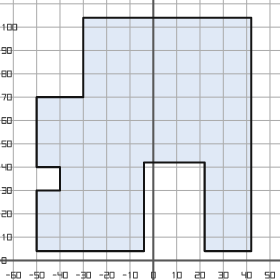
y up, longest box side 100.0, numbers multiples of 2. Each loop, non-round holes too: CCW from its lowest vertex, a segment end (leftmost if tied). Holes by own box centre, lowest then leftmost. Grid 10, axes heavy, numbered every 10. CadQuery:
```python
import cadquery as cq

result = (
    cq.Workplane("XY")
    .moveTo(-50.0, 4.0)
    .lineTo(-4.0, 4.0)
    .lineTo(-4.0, 42.0)
    .lineTo(22.0, 42.0)
    .lineTo(22.0, 4.0)
    .lineTo(42.0, 4.0)
    .lineTo(42.0, 104.0)
    .lineTo(-30.0, 104.0)
    .lineTo(-30.0, 70.0)
    .lineTo(-50.0, 70.0)
    .lineTo(-50.0, 40.0)
    .lineTo(-40.0, 40.0)
    .lineTo(-40.0, 30.0)
    .lineTo(-50.0, 30.0)
    .close()
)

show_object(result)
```